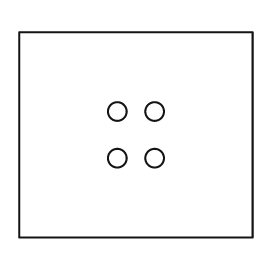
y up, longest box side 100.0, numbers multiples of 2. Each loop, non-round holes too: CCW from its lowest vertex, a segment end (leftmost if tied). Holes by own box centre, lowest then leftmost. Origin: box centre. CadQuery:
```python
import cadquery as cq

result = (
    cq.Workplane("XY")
    .moveTo(-50.0, -44.0)
    .lineTo(50.0, -44.0)
    .lineTo(50.0, 44.0)
    .lineTo(-50.0, 44.0)
    .close()
    .moveTo(-8.0, -10.0)
    .circle(4.0)
    .moveTo(8.0, -10.0)
    .circle(4.0)
    .moveTo(-8.0, 10.0)
    .circle(4.0)
    .moveTo(8.0, 10.0)
    .circle(4.0)
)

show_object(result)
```